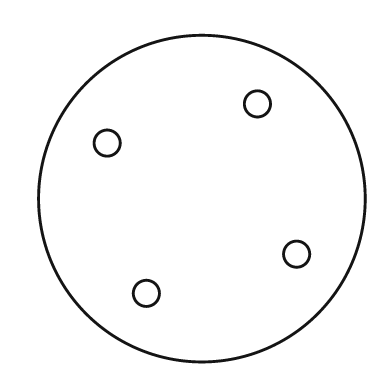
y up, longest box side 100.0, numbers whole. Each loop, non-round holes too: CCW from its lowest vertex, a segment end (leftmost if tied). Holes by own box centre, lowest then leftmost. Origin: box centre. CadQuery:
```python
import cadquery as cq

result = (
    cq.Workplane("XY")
    .moveTo(0.0, 0.0)
    .circle(50.0)
    .moveTo(-17.0, -29.0)
    .circle(4.0)
    .moveTo(29.0, -17.0)
    .circle(4.0)
    .moveTo(-29.0, 17.0)
    .circle(4.0)
    .moveTo(17.0, 29.0)
    .circle(4.0)
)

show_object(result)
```